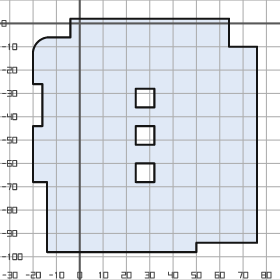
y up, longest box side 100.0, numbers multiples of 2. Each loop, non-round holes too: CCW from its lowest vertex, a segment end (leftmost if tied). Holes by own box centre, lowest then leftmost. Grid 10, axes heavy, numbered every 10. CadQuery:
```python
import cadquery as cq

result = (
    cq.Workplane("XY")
    .moveTo(-14.0, -98.0)
    .lineTo(50.0, -98.0)
    .lineTo(50.0, -94.0)
    .lineTo(76.0, -94.0)
    .lineTo(76.0, -10.0)
    .lineTo(64.0, -10.0)
    .lineTo(64.0, 2.0)
    .lineTo(-4.0, 2.0)
    .lineTo(-4.0, -6.0)
    .lineTo(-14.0, -6.0)
    .threePointArc((-18.0, -8.0), (-20.0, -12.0))
    .lineTo(-20.0, -26.0)
    .lineTo(-16.0, -26.0)
    .lineTo(-16.0, -44.0)
    .lineTo(-20.0, -44.0)
    .lineTo(-20.0, -68.0)
    .lineTo(-14.0, -68.0)
    .close()
    .moveTo(24.0, -68.0)
    .lineTo(32.0, -68.0)
    .lineTo(32.0, -60.0)
    .lineTo(24.0, -60.0)
    .close()
    .moveTo(24.0, -52.0)
    .lineTo(32.0, -52.0)
    .lineTo(32.0, -44.0)
    .lineTo(24.0, -44.0)
    .close()
    .moveTo(24.0, -36.0)
    .lineTo(32.0, -36.0)
    .lineTo(32.0, -28.0)
    .lineTo(24.0, -28.0)
    .close()
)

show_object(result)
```